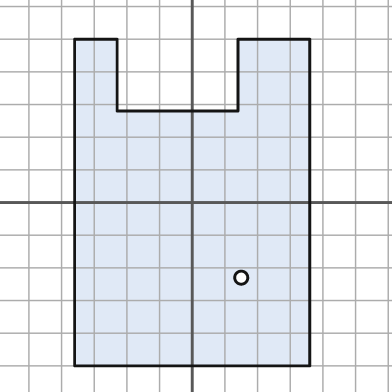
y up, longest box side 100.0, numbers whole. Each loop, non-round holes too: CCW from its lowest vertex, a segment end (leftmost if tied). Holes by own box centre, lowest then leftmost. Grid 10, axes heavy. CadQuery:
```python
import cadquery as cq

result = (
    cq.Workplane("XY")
    .moveTo(-36.0, -50.0)
    .lineTo(36.0, -50.0)
    .lineTo(36.0, 50.0)
    .lineTo(14.0, 50.0)
    .lineTo(14.0, 28.0)
    .lineTo(-23.0, 28.0)
    .lineTo(-23.0, 50.0)
    .lineTo(-36.0, 50.0)
    .close()
    .moveTo(15.0, -23.0)
    .circle(2.0)
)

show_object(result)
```